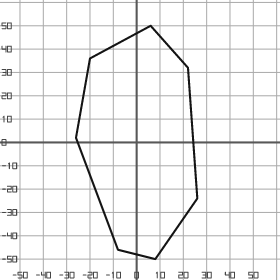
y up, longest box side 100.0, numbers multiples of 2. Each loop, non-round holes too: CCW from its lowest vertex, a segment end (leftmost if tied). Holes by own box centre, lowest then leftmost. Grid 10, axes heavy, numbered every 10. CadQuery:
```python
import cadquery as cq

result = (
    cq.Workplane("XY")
    .moveTo(8.0, -50.0)
    .lineTo(26.0, -24.0)
    .lineTo(22.0, 32.0)
    .lineTo(6.0, 50.0)
    .lineTo(-20.0, 36.0)
    .lineTo(-26.0, 2.0)
    .lineTo(-8.0, -46.0)
    .close()
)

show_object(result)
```